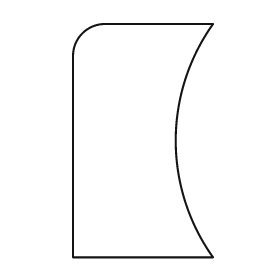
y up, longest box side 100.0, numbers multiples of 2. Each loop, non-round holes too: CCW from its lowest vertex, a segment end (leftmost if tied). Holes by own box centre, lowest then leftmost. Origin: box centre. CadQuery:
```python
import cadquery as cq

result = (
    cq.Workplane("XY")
    .moveTo(-30.0, -50.0)
    .lineTo(30.0, -50.0)
    .threePointArc((14.0, 0.0), (30.0, 50.0))
    .lineTo(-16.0, 50.0)
    .threePointArc((-26.0, 46.0), (-30.0, 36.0))
    .close()
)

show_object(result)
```